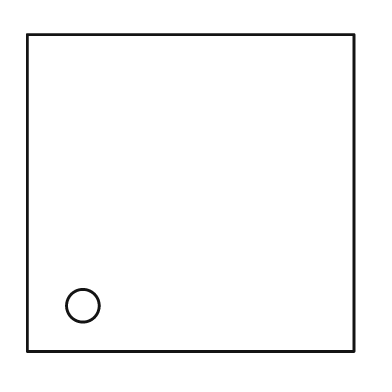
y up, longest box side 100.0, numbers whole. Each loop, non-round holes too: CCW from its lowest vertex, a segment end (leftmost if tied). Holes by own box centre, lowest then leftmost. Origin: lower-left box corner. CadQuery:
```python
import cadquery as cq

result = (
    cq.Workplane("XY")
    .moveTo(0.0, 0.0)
    .lineTo(100.0, 0.0)
    .lineTo(100.0, 97.0)
    .lineTo(0.0, 97.0)
    .close()
    .moveTo(17.0, 14.0)
    .circle(5.0)
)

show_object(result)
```